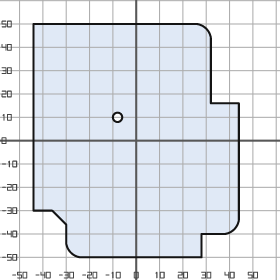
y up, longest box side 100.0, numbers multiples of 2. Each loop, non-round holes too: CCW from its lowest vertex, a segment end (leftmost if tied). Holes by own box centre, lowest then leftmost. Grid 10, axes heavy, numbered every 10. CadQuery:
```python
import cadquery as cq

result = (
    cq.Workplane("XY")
    .moveTo(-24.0, -50.0)
    .lineTo(28.0, -50.0)
    .lineTo(28.0, -40.0)
    .lineTo(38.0, -40.0)
    .threePointArc((42.0, -38.0), (44.0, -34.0))
    .lineTo(44.0, 16.0)
    .lineTo(32.0, 16.0)
    .lineTo(32.0, 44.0)
    .threePointArc((30.0, 48.0), (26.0, 50.0))
    .lineTo(-44.0, 50.0)
    .lineTo(-44.0, -30.0)
    .lineTo(-36.0, -30.0)
    .lineTo(-30.0, -36.0)
    .lineTo(-30.0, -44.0)
    .threePointArc((-28.0, -48.0), (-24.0, -50.0))
    .close()
    .moveTo(-8.0, 10.0)
    .circle(2.0)
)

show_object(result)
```